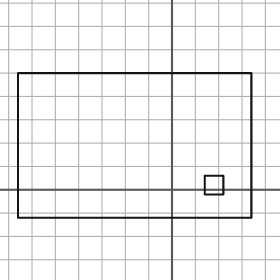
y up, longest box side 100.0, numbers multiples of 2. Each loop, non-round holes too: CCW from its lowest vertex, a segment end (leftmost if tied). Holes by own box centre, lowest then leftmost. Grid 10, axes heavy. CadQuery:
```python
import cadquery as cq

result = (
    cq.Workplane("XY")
    .moveTo(-66.0, -12.0)
    .lineTo(34.0, -12.0)
    .lineTo(34.0, 50.0)
    .lineTo(-66.0, 50.0)
    .close()
    .moveTo(14.0, -2.0)
    .lineTo(22.0, -2.0)
    .lineTo(22.0, 6.0)
    .lineTo(14.0, 6.0)
    .close()
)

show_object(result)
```